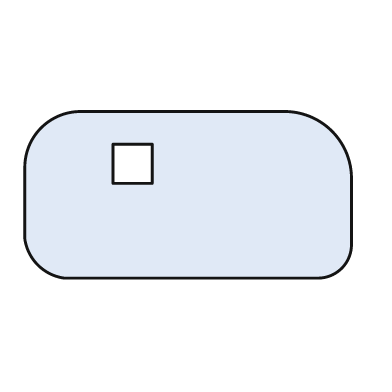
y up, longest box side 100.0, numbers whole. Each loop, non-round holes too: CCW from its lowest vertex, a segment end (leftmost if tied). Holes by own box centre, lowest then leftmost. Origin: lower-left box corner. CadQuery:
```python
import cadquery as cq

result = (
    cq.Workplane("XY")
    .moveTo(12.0, 0.0)
    .lineTo(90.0, 0.0)
    .threePointArc((97.0, 3.0), (100.0, 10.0))
    .lineTo(100.0, 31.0)
    .threePointArc((94.0, 45.0), (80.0, 51.0))
    .lineTo(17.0, 51.0)
    .threePointArc((5.0, 46.0), (0.0, 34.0))
    .lineTo(0.0, 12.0)
    .threePointArc((4.0, 4.0), (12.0, 0.0))
    .close()
    .moveTo(27.0, 29.0)
    .lineTo(39.0, 29.0)
    .lineTo(39.0, 41.0)
    .lineTo(27.0, 41.0)
    .close()
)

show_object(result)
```